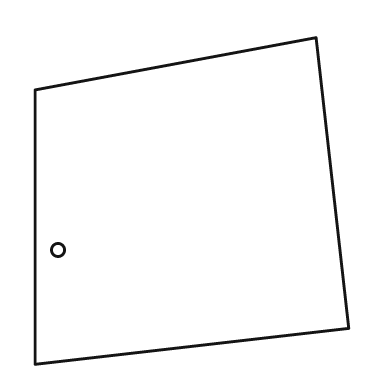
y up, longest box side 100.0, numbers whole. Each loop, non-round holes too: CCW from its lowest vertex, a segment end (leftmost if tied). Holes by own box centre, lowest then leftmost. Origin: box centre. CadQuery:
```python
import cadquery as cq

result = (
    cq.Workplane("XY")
    .moveTo(-48.0, -50.0)
    .lineTo(48.0, -39.0)
    .lineTo(38.0, 50.0)
    .lineTo(-48.0, 34.0)
    .close()
    .moveTo(-41.0, -15.0)
    .circle(2.0)
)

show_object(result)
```